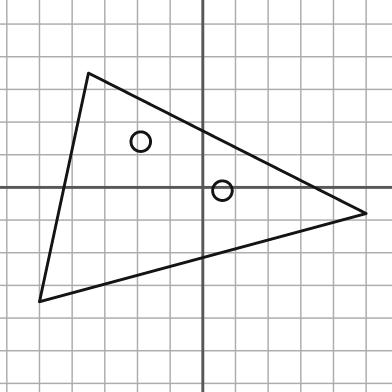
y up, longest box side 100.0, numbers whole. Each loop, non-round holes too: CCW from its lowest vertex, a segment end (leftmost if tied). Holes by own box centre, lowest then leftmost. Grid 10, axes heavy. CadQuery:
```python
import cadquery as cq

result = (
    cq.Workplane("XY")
    .moveTo(-50.0, -35.0)
    .lineTo(50.0, -8.0)
    .lineTo(-35.0, 35.0)
    .close()
    .moveTo(6.0, -1.0)
    .circle(3.0)
    .moveTo(-19.0, 14.0)
    .circle(3.0)
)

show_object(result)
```